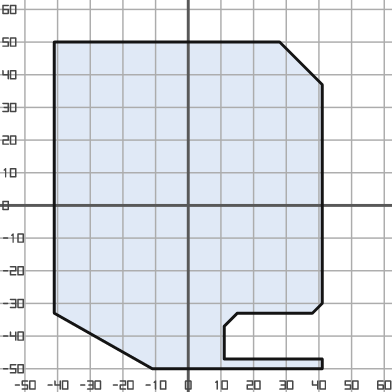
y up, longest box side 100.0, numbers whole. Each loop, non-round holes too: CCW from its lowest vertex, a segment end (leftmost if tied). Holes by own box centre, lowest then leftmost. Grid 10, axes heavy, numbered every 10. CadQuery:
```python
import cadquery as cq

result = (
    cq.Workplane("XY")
    .moveTo(-11.0, -50.0)
    .lineTo(41.0, -50.0)
    .lineTo(41.0, -47.0)
    .lineTo(11.0, -47.0)
    .lineTo(11.0, -37.0)
    .lineTo(15.0, -33.0)
    .lineTo(38.0, -33.0)
    .lineTo(41.0, -30.0)
    .lineTo(41.0, 37.0)
    .lineTo(28.0, 50.0)
    .lineTo(-41.0, 50.0)
    .lineTo(-41.0, -33.0)
    .close()
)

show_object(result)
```